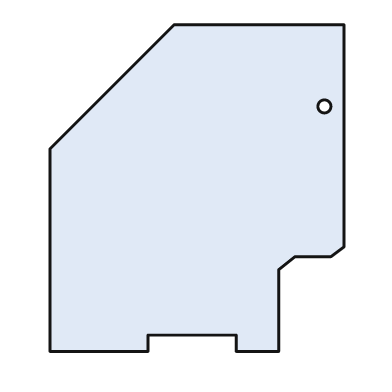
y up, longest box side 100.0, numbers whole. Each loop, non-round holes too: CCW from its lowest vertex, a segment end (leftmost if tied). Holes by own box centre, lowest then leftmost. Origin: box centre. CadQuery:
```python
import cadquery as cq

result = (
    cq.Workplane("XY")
    .moveTo(-45.0, -50.0)
    .lineTo(-15.0, -50.0)
    .lineTo(-15.0, -45.0)
    .lineTo(12.0, -45.0)
    .lineTo(12.0, -50.0)
    .lineTo(25.0, -50.0)
    .lineTo(25.0, -25.0)
    .lineTo(30.0, -21.0)
    .lineTo(41.0, -21.0)
    .lineTo(45.0, -18.0)
    .lineTo(45.0, 50.0)
    .lineTo(-7.0, 50.0)
    .lineTo(-45.0, 12.0)
    .close()
    .moveTo(39.0, 25.0)
    .circle(2.0)
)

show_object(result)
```